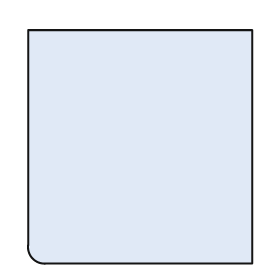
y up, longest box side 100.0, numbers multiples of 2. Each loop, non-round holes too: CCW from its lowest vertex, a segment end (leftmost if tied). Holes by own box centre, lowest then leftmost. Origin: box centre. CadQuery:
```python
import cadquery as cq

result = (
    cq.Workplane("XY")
    .moveTo(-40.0, -50.0)
    .lineTo(48.0, -50.0)
    .lineTo(48.0, 50.0)
    .lineTo(-48.0, 50.0)
    .lineTo(-48.0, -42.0)
    .threePointArc((-46.0, -48.0), (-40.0, -50.0))
    .close()
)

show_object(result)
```